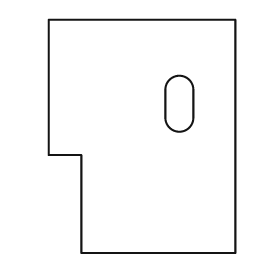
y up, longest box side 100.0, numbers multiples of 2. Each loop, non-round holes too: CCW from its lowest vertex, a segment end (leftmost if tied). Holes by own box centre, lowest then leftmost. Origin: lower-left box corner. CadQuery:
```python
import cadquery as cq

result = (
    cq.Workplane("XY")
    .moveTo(14.0, 0.0)
    .lineTo(80.0, 0.0)
    .lineTo(80.0, 100.0)
    .lineTo(0.0, 100.0)
    .lineTo(0.0, 42.0)
    .lineTo(14.0, 42.0)
    .close()
    .moveTo(50.0, 58.0)
    .threePointArc((56.0, 52.0), (62.0, 58.0))
    .lineTo(62.0, 70.0)
    .threePointArc((56.0, 76.0), (50.0, 70.0))
    .close()
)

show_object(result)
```